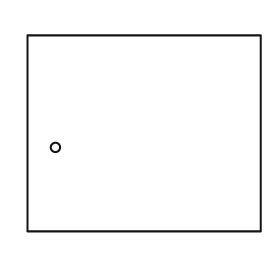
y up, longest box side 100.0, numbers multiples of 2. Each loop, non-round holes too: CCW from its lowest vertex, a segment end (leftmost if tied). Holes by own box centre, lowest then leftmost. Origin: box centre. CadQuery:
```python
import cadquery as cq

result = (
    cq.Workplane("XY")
    .moveTo(-50.0, -42.0)
    .lineTo(50.0, -42.0)
    .lineTo(50.0, 42.0)
    .lineTo(-50.0, 42.0)
    .close()
    .moveTo(-38.0, -6.0)
    .circle(2.0)
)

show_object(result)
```